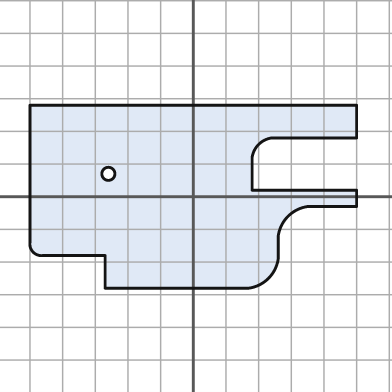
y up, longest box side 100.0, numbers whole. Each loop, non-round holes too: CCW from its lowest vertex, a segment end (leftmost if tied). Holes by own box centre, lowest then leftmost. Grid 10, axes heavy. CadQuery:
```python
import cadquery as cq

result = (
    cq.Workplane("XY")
    .moveTo(-27.0, -28.0)
    .lineTo(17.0, -28.0)
    .threePointArc((23.0, -25.0), (26.0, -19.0))
    .lineTo(26.0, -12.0)
    .threePointArc((29.0, -6.0), (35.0, -3.0))
    .lineTo(50.0, -3.0)
    .lineTo(50.0, 2.0)
    .lineTo(18.0, 2.0)
    .lineTo(18.0, 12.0)
    .threePointArc((20.0, 16.0), (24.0, 18.0))
    .lineTo(50.0, 18.0)
    .lineTo(50.0, 28.0)
    .lineTo(-50.0, 28.0)
    .lineTo(-50.0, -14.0)
    .threePointArc((-49.0, -17.0), (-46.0, -18.0))
    .lineTo(-27.0, -18.0)
    .close()
    .moveTo(-26.0, 7.0)
    .circle(2.0)
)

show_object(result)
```